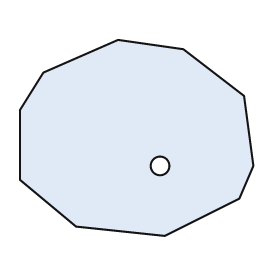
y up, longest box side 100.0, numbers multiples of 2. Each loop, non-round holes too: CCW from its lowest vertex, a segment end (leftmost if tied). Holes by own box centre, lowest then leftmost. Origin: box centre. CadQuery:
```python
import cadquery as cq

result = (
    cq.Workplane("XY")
    .moveTo(12.0, -42.0)
    .lineTo(44.0, -26.0)
    .lineTo(50.0, -12.0)
    .lineTo(46.0, 18.0)
    .lineTo(20.0, 38.0)
    .lineTo(-8.0, 42.0)
    .lineTo(-40.0, 28.0)
    .lineTo(-50.0, 12.0)
    .lineTo(-50.0, -18.0)
    .lineTo(-26.0, -38.0)
    .close()
    .moveTo(10.0, -12.0)
    .circle(4.0)
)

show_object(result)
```